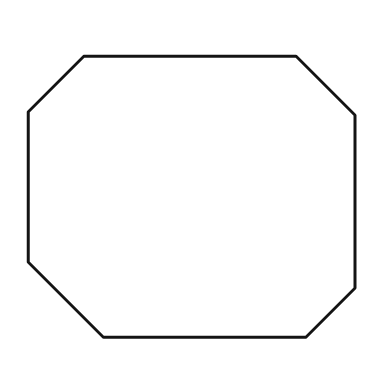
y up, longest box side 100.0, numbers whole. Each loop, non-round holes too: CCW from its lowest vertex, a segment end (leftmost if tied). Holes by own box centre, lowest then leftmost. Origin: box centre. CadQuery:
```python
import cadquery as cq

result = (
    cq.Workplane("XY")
    .moveTo(-27.0, -43.0)
    .lineTo(35.0, -43.0)
    .lineTo(50.0, -28.0)
    .lineTo(50.0, 25.0)
    .lineTo(32.0, 43.0)
    .lineTo(-33.0, 43.0)
    .lineTo(-50.0, 26.0)
    .lineTo(-50.0, -20.0)
    .close()
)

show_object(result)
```